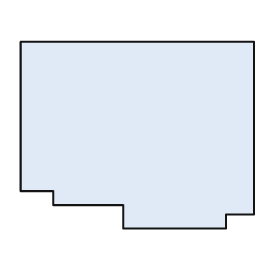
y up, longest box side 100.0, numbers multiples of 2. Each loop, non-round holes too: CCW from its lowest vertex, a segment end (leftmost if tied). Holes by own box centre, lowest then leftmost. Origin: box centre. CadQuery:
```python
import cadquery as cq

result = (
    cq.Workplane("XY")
    .moveTo(-6.0, -40.0)
    .lineTo(38.0, -40.0)
    .lineTo(38.0, -34.0)
    .lineTo(50.0, -34.0)
    .lineTo(50.0, 40.0)
    .lineTo(-50.0, 40.0)
    .lineTo(-50.0, -24.0)
    .lineTo(-36.0, -24.0)
    .lineTo(-36.0, -30.0)
    .lineTo(-6.0, -30.0)
    .close()
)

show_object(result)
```